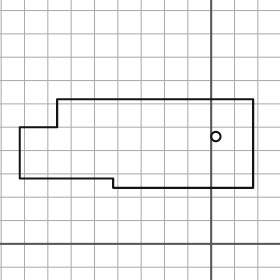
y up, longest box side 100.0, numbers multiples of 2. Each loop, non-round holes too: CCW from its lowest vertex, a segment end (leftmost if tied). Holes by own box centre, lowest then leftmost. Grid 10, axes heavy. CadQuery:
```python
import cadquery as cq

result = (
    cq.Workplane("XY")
    .moveTo(-42.0, 24.0)
    .lineTo(18.0, 24.0)
    .lineTo(18.0, 62.0)
    .lineTo(-66.0, 62.0)
    .lineTo(-66.0, 50.0)
    .lineTo(-82.0, 50.0)
    .lineTo(-82.0, 28.0)
    .lineTo(-42.0, 28.0)
    .close()
    .moveTo(2.0, 46.0)
    .circle(2.0)
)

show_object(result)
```